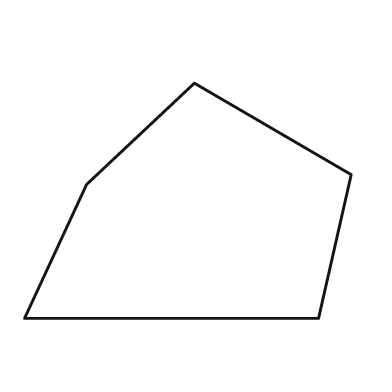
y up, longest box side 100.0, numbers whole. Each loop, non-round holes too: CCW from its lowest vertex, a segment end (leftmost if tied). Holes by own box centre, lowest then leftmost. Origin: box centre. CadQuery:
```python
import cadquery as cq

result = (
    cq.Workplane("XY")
    .moveTo(-50.0, -36.0)
    .lineTo(40.0, -36.0)
    .lineTo(50.0, 8.0)
    .lineTo(2.0, 36.0)
    .lineTo(-31.0, 5.0)
    .close()
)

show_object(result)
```